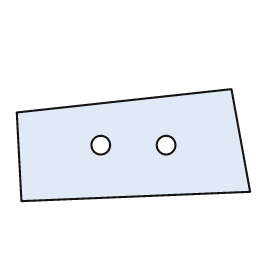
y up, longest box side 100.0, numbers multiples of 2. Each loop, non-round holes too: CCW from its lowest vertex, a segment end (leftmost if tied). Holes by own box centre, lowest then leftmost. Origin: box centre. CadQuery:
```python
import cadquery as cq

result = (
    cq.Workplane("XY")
    .moveTo(-48.0, -24.0)
    .lineTo(50.0, -20.0)
    .lineTo(42.0, 24.0)
    .lineTo(-50.0, 14.0)
    .close()
    .moveTo(-14.0, 0.0)
    .circle(4.0)
    .moveTo(14.0, 0.0)
    .circle(4.0)
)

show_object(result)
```